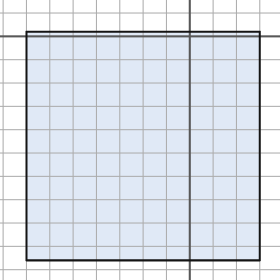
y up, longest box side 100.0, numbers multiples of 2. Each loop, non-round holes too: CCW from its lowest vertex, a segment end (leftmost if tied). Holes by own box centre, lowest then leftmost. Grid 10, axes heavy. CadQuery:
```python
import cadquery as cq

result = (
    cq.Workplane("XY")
    .moveTo(-70.0, -96.0)
    .lineTo(30.0, -96.0)
    .lineTo(30.0, 2.0)
    .lineTo(-70.0, 2.0)
    .close()
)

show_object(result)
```